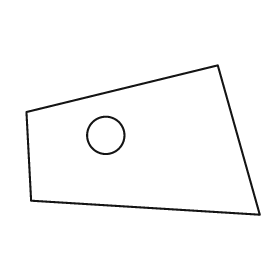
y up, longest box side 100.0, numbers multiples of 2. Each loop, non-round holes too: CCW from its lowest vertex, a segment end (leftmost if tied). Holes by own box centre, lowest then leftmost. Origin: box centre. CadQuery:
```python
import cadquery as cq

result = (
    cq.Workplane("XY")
    .moveTo(50.0, -32.0)
    .lineTo(32.0, 32.0)
    .lineTo(-50.0, 12.0)
    .lineTo(-48.0, -26.0)
    .close()
    .moveTo(-16.0, 2.0)
    .circle(8.0)
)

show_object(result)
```